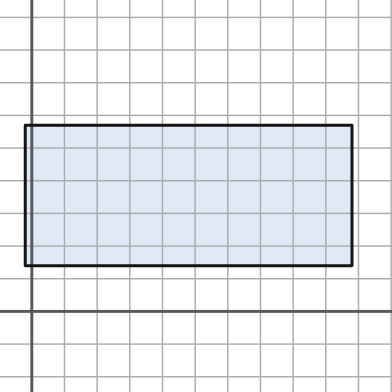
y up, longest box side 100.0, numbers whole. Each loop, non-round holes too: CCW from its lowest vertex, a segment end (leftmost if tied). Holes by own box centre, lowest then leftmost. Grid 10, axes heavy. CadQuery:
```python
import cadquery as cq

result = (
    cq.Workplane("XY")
    .moveTo(-2.0, 14.0)
    .lineTo(98.0, 14.0)
    .lineTo(98.0, 57.0)
    .lineTo(-2.0, 57.0)
    .close()
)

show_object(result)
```